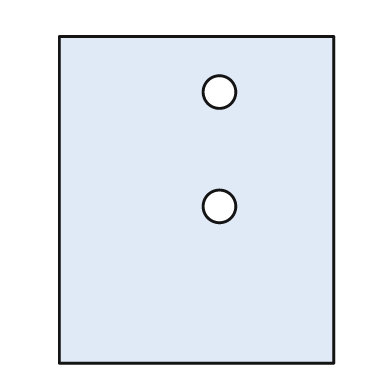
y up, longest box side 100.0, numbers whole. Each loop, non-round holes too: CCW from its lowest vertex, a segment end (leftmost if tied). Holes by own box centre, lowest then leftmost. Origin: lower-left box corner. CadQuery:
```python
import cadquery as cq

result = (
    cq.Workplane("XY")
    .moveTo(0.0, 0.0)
    .lineTo(84.0, 0.0)
    .lineTo(84.0, 100.0)
    .lineTo(0.0, 100.0)
    .close()
    .moveTo(49.0, 48.0)
    .circle(5.0)
    .moveTo(49.0, 83.0)
    .circle(5.0)
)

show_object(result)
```